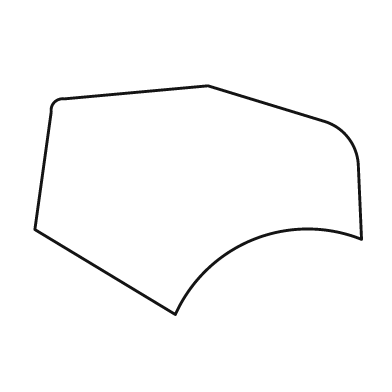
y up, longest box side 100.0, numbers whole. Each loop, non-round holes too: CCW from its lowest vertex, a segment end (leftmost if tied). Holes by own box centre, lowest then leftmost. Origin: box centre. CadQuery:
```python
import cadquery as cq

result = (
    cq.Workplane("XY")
    .moveTo(-7.0, -35.0)
    .threePointArc((17.0, -12.0), (50.0, -12.0))
    .lineTo(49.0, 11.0)
    .threePointArc((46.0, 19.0), (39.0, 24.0))
    .lineTo(3.0, 35.0)
    .lineTo(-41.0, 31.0)
    .threePointArc((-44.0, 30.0), (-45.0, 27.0))
    .lineTo(-50.0, -9.0)
    .close()
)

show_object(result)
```